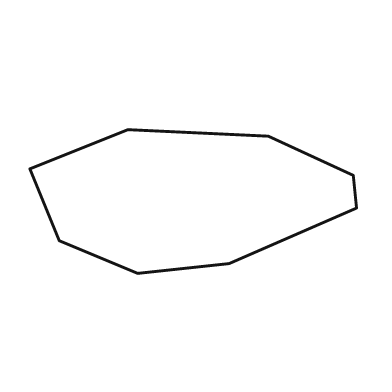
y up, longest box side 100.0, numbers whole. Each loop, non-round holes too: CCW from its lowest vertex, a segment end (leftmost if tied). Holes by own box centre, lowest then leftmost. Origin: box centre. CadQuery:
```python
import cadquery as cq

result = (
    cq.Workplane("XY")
    .moveTo(-17.0, -22.0)
    .lineTo(11.0, -19.0)
    .lineTo(50.0, -2.0)
    .lineTo(49.0, 8.0)
    .lineTo(23.0, 20.0)
    .lineTo(-20.0, 22.0)
    .lineTo(-50.0, 10.0)
    .lineTo(-41.0, -12.0)
    .close()
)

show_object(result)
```